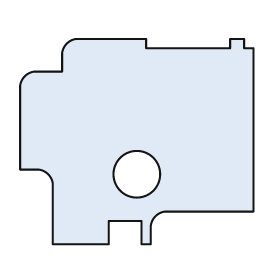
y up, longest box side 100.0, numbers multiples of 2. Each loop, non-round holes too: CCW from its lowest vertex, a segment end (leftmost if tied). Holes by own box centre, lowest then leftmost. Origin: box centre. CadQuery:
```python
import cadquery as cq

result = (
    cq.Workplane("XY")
    .moveTo(-36.0, -44.0)
    .lineTo(-12.0, -44.0)
    .lineTo(-12.0, -34.0)
    .lineTo(2.0, -34.0)
    .lineTo(2.0, -44.0)
    .lineTo(6.0, -44.0)
    .lineTo(6.0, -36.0)
    .threePointArc((8.0, -32.0), (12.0, -30.0))
    .lineTo(50.0, -30.0)
    .lineTo(50.0, 40.0)
    .lineTo(46.0, 40.0)
    .lineTo(46.0, 44.0)
    .lineTo(40.0, 44.0)
    .lineTo(40.0, 40.0)
    .lineTo(4.0, 40.0)
    .lineTo(4.0, 44.0)
    .lineTo(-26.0, 44.0)
    .threePointArc((-30.0, 42.0), (-32.0, 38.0))
    .lineTo(-32.0, 30.0)
    .lineTo(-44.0, 30.0)
    .threePointArc((-48.0, 28.0), (-50.0, 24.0))
    .lineTo(-50.0, -12.0)
    .lineTo(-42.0, -12.0)
    .threePointArc((-38.0, -14.0), (-36.0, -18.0))
    .close()
    .moveTo(0.0, -14.0)
    .circle(10.0)
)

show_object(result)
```